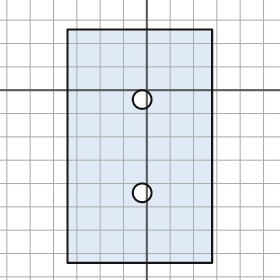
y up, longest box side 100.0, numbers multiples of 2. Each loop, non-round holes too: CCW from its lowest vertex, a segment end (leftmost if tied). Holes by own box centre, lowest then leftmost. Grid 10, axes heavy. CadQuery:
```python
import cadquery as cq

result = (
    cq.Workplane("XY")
    .moveTo(-34.0, -74.0)
    .lineTo(28.0, -74.0)
    .lineTo(28.0, 26.0)
    .lineTo(-34.0, 26.0)
    .close()
    .moveTo(-2.0, -44.0)
    .circle(4.0)
    .moveTo(-2.0, -4.0)
    .circle(4.0)
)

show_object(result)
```